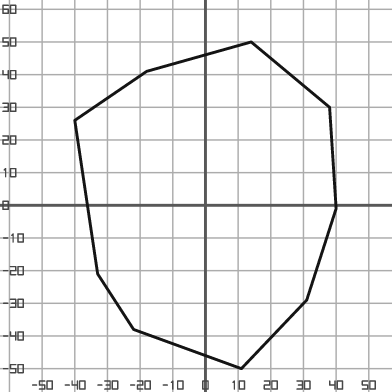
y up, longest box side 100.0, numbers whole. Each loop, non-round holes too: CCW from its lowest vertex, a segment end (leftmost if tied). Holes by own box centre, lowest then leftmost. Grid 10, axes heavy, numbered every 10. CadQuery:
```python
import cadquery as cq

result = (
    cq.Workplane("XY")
    .moveTo(11.0, -50.0)
    .lineTo(31.0, -29.0)
    .lineTo(40.0, -1.0)
    .lineTo(38.0, 30.0)
    .lineTo(14.0, 50.0)
    .lineTo(-18.0, 41.0)
    .lineTo(-40.0, 26.0)
    .lineTo(-33.0, -21.0)
    .lineTo(-22.0, -38.0)
    .close()
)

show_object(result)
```